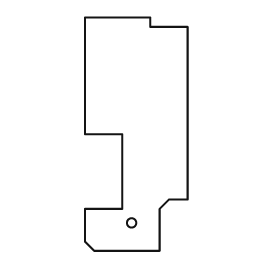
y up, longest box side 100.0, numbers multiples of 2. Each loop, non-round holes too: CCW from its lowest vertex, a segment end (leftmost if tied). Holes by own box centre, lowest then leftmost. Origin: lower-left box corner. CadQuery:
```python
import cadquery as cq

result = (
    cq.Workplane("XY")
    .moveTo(4.0, 0.0)
    .lineTo(32.0, 0.0)
    .lineTo(32.0, 18.0)
    .lineTo(36.0, 22.0)
    .lineTo(44.0, 22.0)
    .lineTo(44.0, 96.0)
    .lineTo(28.0, 96.0)
    .lineTo(28.0, 100.0)
    .lineTo(0.0, 100.0)
    .lineTo(0.0, 50.0)
    .lineTo(16.0, 50.0)
    .lineTo(16.0, 18.0)
    .lineTo(0.0, 18.0)
    .lineTo(0.0, 4.0)
    .close()
    .moveTo(20.0, 12.0)
    .circle(2.0)
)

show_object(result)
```